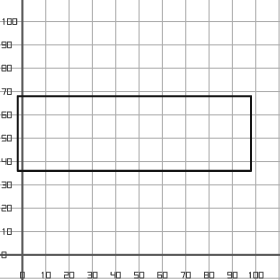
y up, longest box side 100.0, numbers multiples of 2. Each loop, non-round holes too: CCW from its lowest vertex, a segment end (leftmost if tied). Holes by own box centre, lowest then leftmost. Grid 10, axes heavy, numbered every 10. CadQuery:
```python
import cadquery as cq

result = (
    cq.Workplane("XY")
    .moveTo(-2.0, 36.0)
    .lineTo(98.0, 36.0)
    .lineTo(98.0, 68.0)
    .lineTo(-2.0, 68.0)
    .close()
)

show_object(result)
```